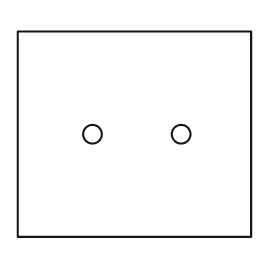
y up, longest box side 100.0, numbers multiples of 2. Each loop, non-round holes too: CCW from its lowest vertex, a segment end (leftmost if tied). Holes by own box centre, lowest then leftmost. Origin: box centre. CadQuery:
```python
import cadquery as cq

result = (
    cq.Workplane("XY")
    .moveTo(-50.0, -44.0)
    .lineTo(50.0, -44.0)
    .lineTo(50.0, 44.0)
    .lineTo(-50.0, 44.0)
    .close()
    .moveTo(-18.0, 0.0)
    .circle(4.0)
    .moveTo(20.0, 0.0)
    .circle(4.0)
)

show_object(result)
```